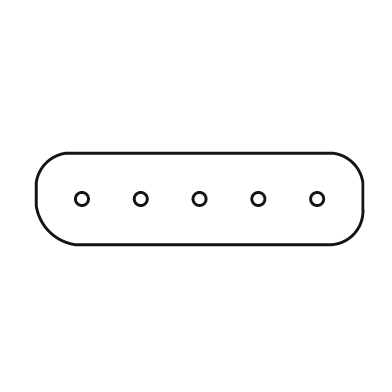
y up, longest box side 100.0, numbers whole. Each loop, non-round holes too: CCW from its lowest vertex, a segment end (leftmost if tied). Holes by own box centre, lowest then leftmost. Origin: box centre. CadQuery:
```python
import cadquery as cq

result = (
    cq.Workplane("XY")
    .moveTo(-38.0, -14.0)
    .lineTo(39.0, -14.0)
    .threePointArc((47.0, -11.0), (50.0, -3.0))
    .lineTo(50.0, 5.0)
    .threePointArc((47.0, 11.0), (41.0, 14.0))
    .lineTo(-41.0, 14.0)
    .threePointArc((-47.0, 11.0), (-50.0, 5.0))
    .lineTo(-50.0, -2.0)
    .threePointArc((-46.0, -10.0), (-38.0, -14.0))
    .close()
    .moveTo(-36.0, 0.0)
    .circle(2.0)
    .moveTo(-18.0, 0.0)
    .circle(2.0)
    .moveTo(0.0, 0.0)
    .circle(2.0)
    .moveTo(18.0, 0.0)
    .circle(2.0)
    .moveTo(36.0, 0.0)
    .circle(2.0)
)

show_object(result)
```